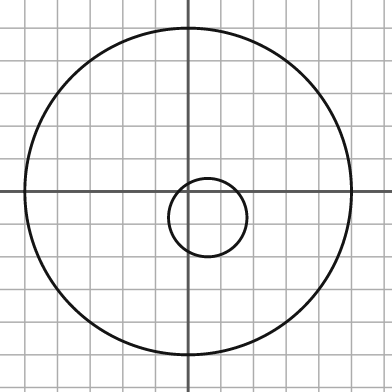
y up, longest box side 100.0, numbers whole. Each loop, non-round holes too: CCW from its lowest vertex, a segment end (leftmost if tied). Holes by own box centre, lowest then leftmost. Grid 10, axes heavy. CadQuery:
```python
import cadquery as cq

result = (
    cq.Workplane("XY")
    .moveTo(0.0, 0.0)
    .circle(50.0)
    .moveTo(6.0, -8.0)
    .circle(12.0)
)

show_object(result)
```